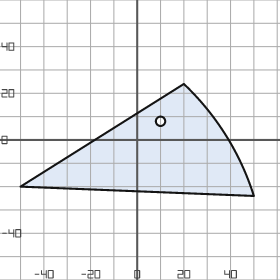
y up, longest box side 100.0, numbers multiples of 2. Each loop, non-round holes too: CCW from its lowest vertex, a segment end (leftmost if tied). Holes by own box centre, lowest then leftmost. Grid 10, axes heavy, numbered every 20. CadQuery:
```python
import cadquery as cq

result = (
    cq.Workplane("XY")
    .moveTo(50.0, -24.0)
    .threePointArc((38.0, 2.0), (20.0, 24.0))
    .lineTo(-50.0, -20.0)
    .close()
    .moveTo(10.0, 8.0)
    .circle(2.0)
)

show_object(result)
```